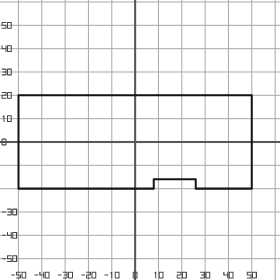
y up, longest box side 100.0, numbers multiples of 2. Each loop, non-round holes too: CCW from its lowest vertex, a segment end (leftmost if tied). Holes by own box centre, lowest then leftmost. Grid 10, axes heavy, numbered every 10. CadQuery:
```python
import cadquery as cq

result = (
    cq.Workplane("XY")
    .moveTo(-50.0, -20.0)
    .lineTo(8.0, -20.0)
    .lineTo(8.0, -16.0)
    .lineTo(26.0, -16.0)
    .lineTo(26.0, -20.0)
    .lineTo(50.0, -20.0)
    .lineTo(50.0, 20.0)
    .lineTo(-50.0, 20.0)
    .close()
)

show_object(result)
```